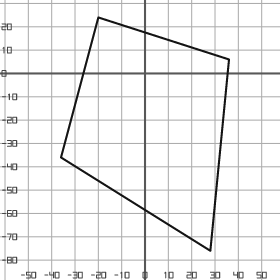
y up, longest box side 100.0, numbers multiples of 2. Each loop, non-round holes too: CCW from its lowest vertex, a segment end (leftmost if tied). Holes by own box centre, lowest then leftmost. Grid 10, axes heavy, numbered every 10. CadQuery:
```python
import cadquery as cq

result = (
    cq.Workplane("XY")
    .moveTo(28.0, -76.0)
    .lineTo(36.0, 6.0)
    .lineTo(-20.0, 24.0)
    .lineTo(-36.0, -36.0)
    .close()
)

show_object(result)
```